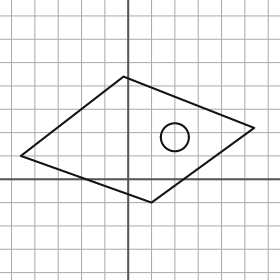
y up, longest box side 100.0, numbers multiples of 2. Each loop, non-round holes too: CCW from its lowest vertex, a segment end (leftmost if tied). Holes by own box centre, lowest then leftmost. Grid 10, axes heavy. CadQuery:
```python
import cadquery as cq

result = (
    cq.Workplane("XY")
    .moveTo(10.0, -10.0)
    .lineTo(54.0, 22.0)
    .lineTo(-2.0, 44.0)
    .lineTo(-46.0, 10.0)
    .close()
    .moveTo(20.0, 18.0)
    .circle(6.0)
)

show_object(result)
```